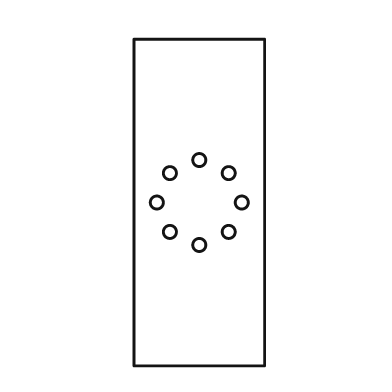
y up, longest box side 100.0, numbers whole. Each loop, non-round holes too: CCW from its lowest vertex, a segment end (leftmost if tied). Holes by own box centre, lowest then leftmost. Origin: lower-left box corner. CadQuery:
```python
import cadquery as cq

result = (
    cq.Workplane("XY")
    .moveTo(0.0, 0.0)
    .lineTo(40.0, 0.0)
    .lineTo(40.0, 100.0)
    .lineTo(0.0, 100.0)
    .close()
    .moveTo(20.0, 37.0)
    .circle(2.0)
    .moveTo(11.0, 41.0)
    .circle(2.0)
    .moveTo(29.0, 41.0)
    .circle(2.0)
    .moveTo(7.0, 50.0)
    .circle(2.0)
    .moveTo(33.0, 50.0)
    .circle(2.0)
    .moveTo(11.0, 59.0)
    .circle(2.0)
    .moveTo(29.0, 59.0)
    .circle(2.0)
    .moveTo(20.0, 63.0)
    .circle(2.0)
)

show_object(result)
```